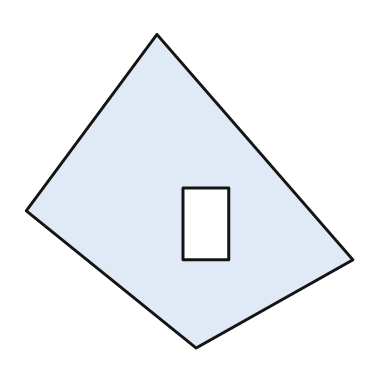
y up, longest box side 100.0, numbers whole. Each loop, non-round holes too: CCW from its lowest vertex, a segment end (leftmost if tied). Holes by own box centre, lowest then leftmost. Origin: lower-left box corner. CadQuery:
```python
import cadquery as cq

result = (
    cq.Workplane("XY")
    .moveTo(52.0, 0.0)
    .lineTo(100.0, 27.0)
    .lineTo(40.0, 96.0)
    .lineTo(0.0, 42.0)
    .close()
    .moveTo(48.0, 27.0)
    .lineTo(62.0, 27.0)
    .lineTo(62.0, 49.0)
    .lineTo(48.0, 49.0)
    .close()
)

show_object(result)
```